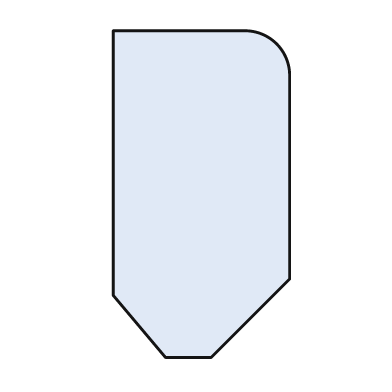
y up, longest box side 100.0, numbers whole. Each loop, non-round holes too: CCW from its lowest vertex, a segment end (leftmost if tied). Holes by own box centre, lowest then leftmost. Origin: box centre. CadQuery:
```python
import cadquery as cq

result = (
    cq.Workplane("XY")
    .moveTo(-11.0, -50.0)
    .lineTo(3.0, -50.0)
    .lineTo(27.0, -26.0)
    .lineTo(27.0, 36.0)
    .threePointArc((23.0, 46.0), (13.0, 50.0))
    .lineTo(-27.0, 50.0)
    .lineTo(-27.0, -31.0)
    .close()
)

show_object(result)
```